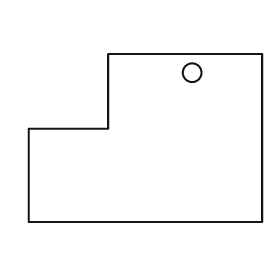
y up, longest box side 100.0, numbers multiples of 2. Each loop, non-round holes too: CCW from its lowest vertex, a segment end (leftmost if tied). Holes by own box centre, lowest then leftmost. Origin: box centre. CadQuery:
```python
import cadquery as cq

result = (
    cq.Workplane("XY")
    .moveTo(-50.0, -36.0)
    .lineTo(50.0, -36.0)
    .lineTo(50.0, 36.0)
    .lineTo(-16.0, 36.0)
    .lineTo(-16.0, 4.0)
    .lineTo(-50.0, 4.0)
    .close()
    .moveTo(20.0, 28.0)
    .circle(4.0)
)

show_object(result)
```